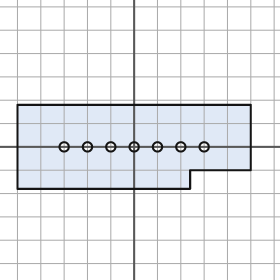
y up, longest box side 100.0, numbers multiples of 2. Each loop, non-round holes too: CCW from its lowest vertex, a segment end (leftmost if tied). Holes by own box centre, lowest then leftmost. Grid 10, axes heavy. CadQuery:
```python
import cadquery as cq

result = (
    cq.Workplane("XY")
    .moveTo(-50.0, -18.0)
    .lineTo(24.0, -18.0)
    .lineTo(24.0, -10.0)
    .lineTo(50.0, -10.0)
    .lineTo(50.0, 18.0)
    .lineTo(-50.0, 18.0)
    .close()
    .moveTo(-30.0, 0.0)
    .circle(2.0)
    .moveTo(-20.0, 0.0)
    .circle(2.0)
    .moveTo(-10.0, 0.0)
    .circle(2.0)
    .moveTo(0.0, 0.0)
    .circle(2.0)
    .moveTo(10.0, 0.0)
    .circle(2.0)
    .moveTo(20.0, 0.0)
    .circle(2.0)
    .moveTo(30.0, 0.0)
    .circle(2.0)
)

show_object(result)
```